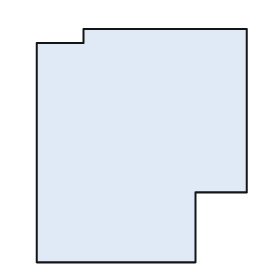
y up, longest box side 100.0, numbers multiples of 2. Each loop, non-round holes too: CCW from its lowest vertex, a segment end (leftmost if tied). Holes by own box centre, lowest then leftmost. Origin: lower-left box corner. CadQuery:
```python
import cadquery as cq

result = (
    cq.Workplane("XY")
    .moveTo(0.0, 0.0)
    .lineTo(68.0, 0.0)
    .lineTo(68.0, 30.0)
    .lineTo(90.0, 30.0)
    .lineTo(90.0, 100.0)
    .lineTo(20.0, 100.0)
    .lineTo(20.0, 94.0)
    .lineTo(0.0, 94.0)
    .close()
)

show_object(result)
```